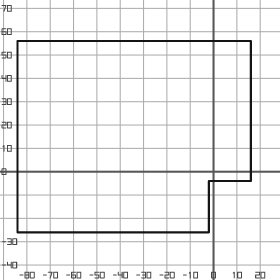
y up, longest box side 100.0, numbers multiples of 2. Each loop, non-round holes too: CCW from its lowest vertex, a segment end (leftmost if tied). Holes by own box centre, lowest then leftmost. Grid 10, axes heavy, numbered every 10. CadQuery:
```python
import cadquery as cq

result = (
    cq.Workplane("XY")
    .moveTo(-84.0, -26.0)
    .lineTo(-2.0, -26.0)
    .lineTo(-2.0, -4.0)
    .lineTo(16.0, -4.0)
    .lineTo(16.0, 56.0)
    .lineTo(-84.0, 56.0)
    .close()
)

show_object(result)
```